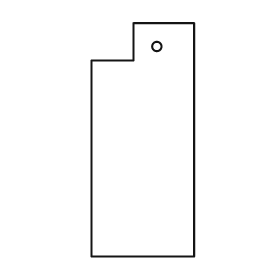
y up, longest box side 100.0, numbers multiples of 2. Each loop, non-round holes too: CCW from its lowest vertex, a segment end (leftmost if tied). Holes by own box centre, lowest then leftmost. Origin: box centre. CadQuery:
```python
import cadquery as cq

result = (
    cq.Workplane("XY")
    .moveTo(-22.0, -50.0)
    .lineTo(22.0, -50.0)
    .lineTo(22.0, 50.0)
    .lineTo(-4.0, 50.0)
    .lineTo(-4.0, 34.0)
    .lineTo(-22.0, 34.0)
    .close()
    .moveTo(6.0, 40.0)
    .circle(2.0)
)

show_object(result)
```